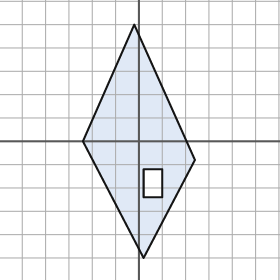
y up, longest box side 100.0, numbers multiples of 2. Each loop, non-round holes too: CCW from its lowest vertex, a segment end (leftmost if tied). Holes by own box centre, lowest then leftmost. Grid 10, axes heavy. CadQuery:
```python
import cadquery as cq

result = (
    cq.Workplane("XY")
    .moveTo(2.0, -50.0)
    .lineTo(24.0, -8.0)
    .lineTo(-2.0, 50.0)
    .lineTo(-24.0, 0.0)
    .close()
    .moveTo(2.0, -24.0)
    .lineTo(10.0, -24.0)
    .lineTo(10.0, -12.0)
    .lineTo(2.0, -12.0)
    .close()
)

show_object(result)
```